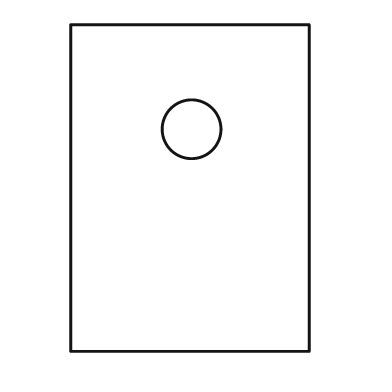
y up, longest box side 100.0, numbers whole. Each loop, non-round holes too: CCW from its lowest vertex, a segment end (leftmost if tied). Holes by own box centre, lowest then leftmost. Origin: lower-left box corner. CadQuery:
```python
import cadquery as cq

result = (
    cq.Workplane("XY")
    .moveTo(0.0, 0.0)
    .lineTo(73.0, 0.0)
    .lineTo(73.0, 100.0)
    .lineTo(0.0, 100.0)
    .close()
    .moveTo(37.0, 68.0)
    .circle(9.0)
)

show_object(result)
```